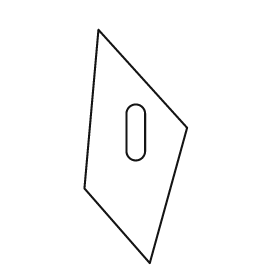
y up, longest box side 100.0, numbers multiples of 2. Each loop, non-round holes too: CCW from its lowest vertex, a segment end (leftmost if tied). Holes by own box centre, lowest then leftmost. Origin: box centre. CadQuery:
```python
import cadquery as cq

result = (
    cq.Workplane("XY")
    .moveTo(6.0, -50.0)
    .lineTo(22.0, 8.0)
    .lineTo(-16.0, 50.0)
    .lineTo(-22.0, -18.0)
    .close()
    .moveTo(-4.0, -2.0)
    .threePointArc((0.0, -6.0), (4.0, -2.0))
    .lineTo(4.0, 14.0)
    .threePointArc((0.0, 18.0), (-4.0, 14.0))
    .close()
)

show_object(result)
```